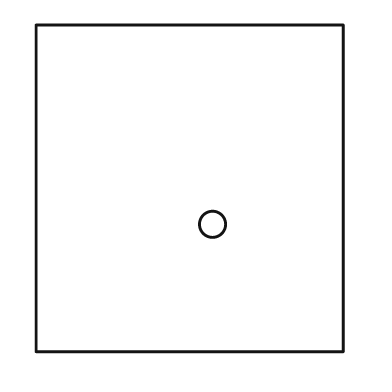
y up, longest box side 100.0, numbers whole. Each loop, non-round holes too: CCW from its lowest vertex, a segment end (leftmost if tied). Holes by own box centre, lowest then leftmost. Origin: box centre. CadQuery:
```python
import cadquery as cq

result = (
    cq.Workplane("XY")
    .moveTo(-47.0, -50.0)
    .lineTo(47.0, -50.0)
    .lineTo(47.0, 50.0)
    .lineTo(-47.0, 50.0)
    .close()
    .moveTo(7.0, -11.0)
    .circle(4.0)
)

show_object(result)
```